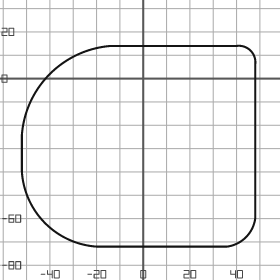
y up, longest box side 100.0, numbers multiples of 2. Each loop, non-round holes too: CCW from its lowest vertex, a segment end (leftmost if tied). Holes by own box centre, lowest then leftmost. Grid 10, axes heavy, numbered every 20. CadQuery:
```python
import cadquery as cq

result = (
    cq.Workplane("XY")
    .moveTo(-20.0, -72.0)
    .lineTo(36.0, -72.0)
    .threePointArc((44.0, -68.0), (48.0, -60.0))
    .lineTo(48.0, 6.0)
    .threePointArc((46.0, 12.0), (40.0, 14.0))
    .lineTo(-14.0, 14.0)
    .threePointArc((-40.0, 2.0), (-52.0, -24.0))
    .lineTo(-52.0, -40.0)
    .threePointArc((-42.0, -62.0), (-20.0, -72.0))
    .close()
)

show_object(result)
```